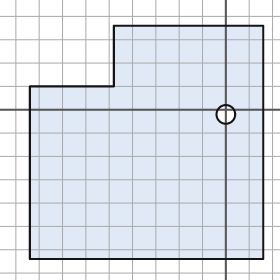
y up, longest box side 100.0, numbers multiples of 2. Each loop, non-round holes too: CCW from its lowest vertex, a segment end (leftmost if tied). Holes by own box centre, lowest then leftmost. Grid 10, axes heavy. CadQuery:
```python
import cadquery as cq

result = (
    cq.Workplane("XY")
    .moveTo(-84.0, -64.0)
    .lineTo(16.0, -64.0)
    .lineTo(16.0, 36.0)
    .lineTo(-48.0, 36.0)
    .lineTo(-48.0, 10.0)
    .lineTo(-84.0, 10.0)
    .close()
    .moveTo(0.0, -2.0)
    .circle(4.0)
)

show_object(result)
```